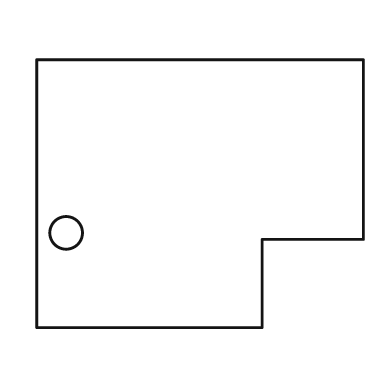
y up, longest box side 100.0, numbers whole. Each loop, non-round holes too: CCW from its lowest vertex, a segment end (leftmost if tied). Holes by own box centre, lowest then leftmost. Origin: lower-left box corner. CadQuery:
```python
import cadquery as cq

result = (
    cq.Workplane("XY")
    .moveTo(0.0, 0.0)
    .lineTo(69.0, 0.0)
    .lineTo(69.0, 27.0)
    .lineTo(100.0, 27.0)
    .lineTo(100.0, 82.0)
    .lineTo(0.0, 82.0)
    .close()
    .moveTo(9.0, 29.0)
    .circle(5.0)
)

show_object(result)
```